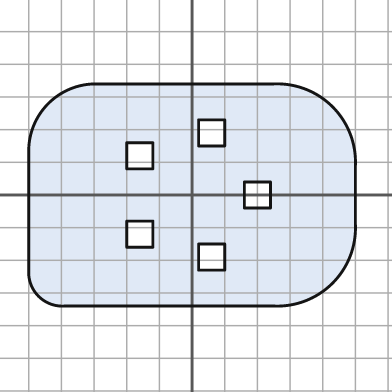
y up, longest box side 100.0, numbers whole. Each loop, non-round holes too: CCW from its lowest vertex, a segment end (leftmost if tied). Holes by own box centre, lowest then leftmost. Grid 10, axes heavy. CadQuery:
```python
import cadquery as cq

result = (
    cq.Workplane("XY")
    .moveTo(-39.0, -34.0)
    .lineTo(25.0, -34.0)
    .threePointArc((43.0, -27.0), (50.0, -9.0))
    .lineTo(50.0, 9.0)
    .threePointArc((43.0, 27.0), (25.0, 34.0))
    .lineTo(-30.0, 34.0)
    .threePointArc((-44.0, 28.0), (-50.0, 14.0))
    .lineTo(-50.0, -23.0)
    .threePointArc((-47.0, -31.0), (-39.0, -34.0))
    .close()
    .moveTo(2.0, -23.0)
    .lineTo(10.0, -23.0)
    .lineTo(10.0, -15.0)
    .lineTo(2.0, -15.0)
    .close()
    .moveTo(-20.0, -16.0)
    .lineTo(-12.0, -16.0)
    .lineTo(-12.0, -8.0)
    .lineTo(-20.0, -8.0)
    .close()
    .moveTo(16.0, -4.0)
    .lineTo(24.0, -4.0)
    .lineTo(24.0, 4.0)
    .lineTo(16.0, 4.0)
    .close()
    .moveTo(-20.0, 8.0)
    .lineTo(-12.0, 8.0)
    .lineTo(-12.0, 16.0)
    .lineTo(-20.0, 16.0)
    .close()
    .moveTo(2.0, 15.0)
    .lineTo(10.0, 15.0)
    .lineTo(10.0, 23.0)
    .lineTo(2.0, 23.0)
    .close()
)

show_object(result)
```